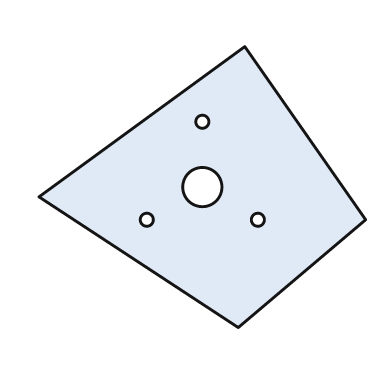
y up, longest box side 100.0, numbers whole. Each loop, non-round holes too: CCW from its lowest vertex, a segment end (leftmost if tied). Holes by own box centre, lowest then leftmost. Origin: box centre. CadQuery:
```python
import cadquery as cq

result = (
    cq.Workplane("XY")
    .moveTo(11.0, -43.0)
    .lineTo(50.0, -10.0)
    .lineTo(13.0, 43.0)
    .lineTo(-50.0, -3.0)
    .close()
    .moveTo(-17.0, -10.0)
    .circle(2.0)
    .moveTo(17.0, -10.0)
    .circle(2.0)
    .moveTo(0.0, 0.0)
    .circle(6.0)
    .moveTo(0.0, 20.0)
    .circle(2.0)
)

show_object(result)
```